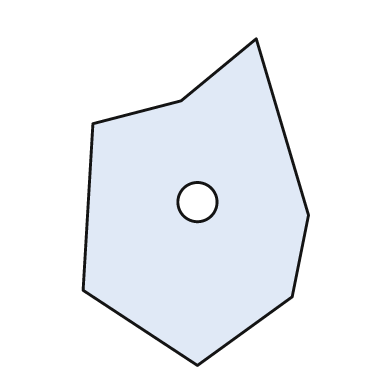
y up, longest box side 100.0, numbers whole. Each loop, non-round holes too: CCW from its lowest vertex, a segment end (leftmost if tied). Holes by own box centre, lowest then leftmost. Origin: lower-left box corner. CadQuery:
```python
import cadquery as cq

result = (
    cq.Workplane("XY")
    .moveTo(35.0, 0.0)
    .lineTo(64.0, 21.0)
    .lineTo(69.0, 46.0)
    .lineTo(53.0, 100.0)
    .lineTo(30.0, 81.0)
    .lineTo(3.0, 74.0)
    .lineTo(0.0, 23.0)
    .close()
    .moveTo(35.0, 50.0)
    .circle(6.0)
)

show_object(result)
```